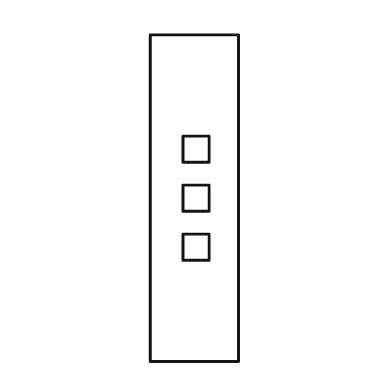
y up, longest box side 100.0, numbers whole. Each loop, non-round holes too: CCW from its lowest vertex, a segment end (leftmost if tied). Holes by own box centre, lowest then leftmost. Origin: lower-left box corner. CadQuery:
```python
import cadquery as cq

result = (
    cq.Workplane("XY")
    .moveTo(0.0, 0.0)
    .lineTo(27.0, 0.0)
    .lineTo(27.0, 100.0)
    .lineTo(0.0, 100.0)
    .close()
    .moveTo(10.0, 31.0)
    .lineTo(18.0, 31.0)
    .lineTo(18.0, 39.0)
    .lineTo(10.0, 39.0)
    .close()
    .moveTo(10.0, 46.0)
    .lineTo(18.0, 46.0)
    .lineTo(18.0, 54.0)
    .lineTo(10.0, 54.0)
    .close()
    .moveTo(10.0, 61.0)
    .lineTo(18.0, 61.0)
    .lineTo(18.0, 69.0)
    .lineTo(10.0, 69.0)
    .close()
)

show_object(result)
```